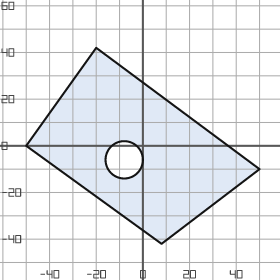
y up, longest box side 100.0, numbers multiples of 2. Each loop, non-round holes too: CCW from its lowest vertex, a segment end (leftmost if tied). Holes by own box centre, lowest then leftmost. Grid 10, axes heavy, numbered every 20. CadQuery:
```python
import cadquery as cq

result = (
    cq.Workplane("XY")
    .moveTo(8.0, -42.0)
    .lineTo(50.0, -10.0)
    .lineTo(-20.0, 42.0)
    .lineTo(-50.0, 0.0)
    .close()
    .moveTo(-8.0, -6.0)
    .circle(8.0)
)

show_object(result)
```